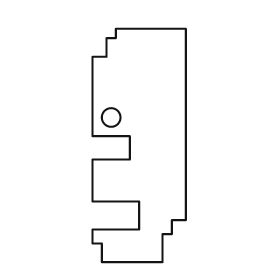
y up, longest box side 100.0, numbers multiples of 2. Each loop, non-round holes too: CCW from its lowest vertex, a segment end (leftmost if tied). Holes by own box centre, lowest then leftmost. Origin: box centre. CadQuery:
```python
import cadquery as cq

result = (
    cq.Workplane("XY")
    .moveTo(-16.0, -50.0)
    .lineTo(10.0, -50.0)
    .lineTo(10.0, -38.0)
    .lineTo(14.0, -38.0)
    .lineTo(14.0, -32.0)
    .lineTo(20.0, -32.0)
    .lineTo(20.0, 50.0)
    .lineTo(-10.0, 50.0)
    .lineTo(-10.0, 46.0)
    .lineTo(-14.0, 46.0)
    .lineTo(-14.0, 38.0)
    .lineTo(-20.0, 38.0)
    .lineTo(-20.0, 4.0)
    .lineTo(-4.0, 4.0)
    .lineTo(-4.0, -6.0)
    .lineTo(-20.0, -6.0)
    .lineTo(-20.0, -24.0)
    .lineTo(0.0, -24.0)
    .lineTo(0.0, -36.0)
    .lineTo(-20.0, -36.0)
    .lineTo(-20.0, -42.0)
    .lineTo(-16.0, -42.0)
    .close()
    .moveTo(-12.0, 12.0)
    .circle(4.0)
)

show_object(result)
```